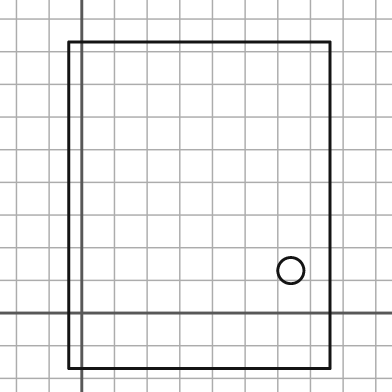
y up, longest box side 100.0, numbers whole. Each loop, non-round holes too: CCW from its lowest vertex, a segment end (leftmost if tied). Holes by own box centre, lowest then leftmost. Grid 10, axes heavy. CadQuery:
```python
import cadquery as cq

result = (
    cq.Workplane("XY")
    .moveTo(-4.0, -17.0)
    .lineTo(76.0, -17.0)
    .lineTo(76.0, 83.0)
    .lineTo(-4.0, 83.0)
    .close()
    .moveTo(64.0, 13.0)
    .circle(4.0)
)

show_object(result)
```